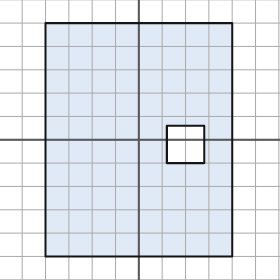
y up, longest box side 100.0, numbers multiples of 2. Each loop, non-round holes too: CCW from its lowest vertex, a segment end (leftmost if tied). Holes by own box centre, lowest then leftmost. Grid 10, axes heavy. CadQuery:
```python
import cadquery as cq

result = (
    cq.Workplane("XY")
    .moveTo(-40.0, -50.0)
    .lineTo(40.0, -50.0)
    .lineTo(40.0, 50.0)
    .lineTo(-40.0, 50.0)
    .close()
    .moveTo(12.0, -10.0)
    .lineTo(28.0, -10.0)
    .lineTo(28.0, 6.0)
    .lineTo(12.0, 6.0)
    .close()
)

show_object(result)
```